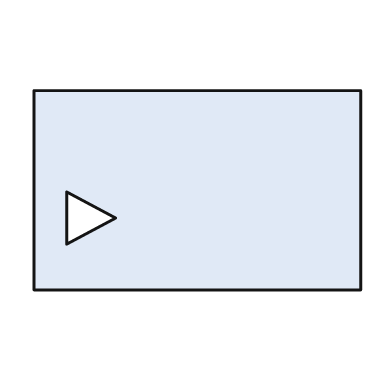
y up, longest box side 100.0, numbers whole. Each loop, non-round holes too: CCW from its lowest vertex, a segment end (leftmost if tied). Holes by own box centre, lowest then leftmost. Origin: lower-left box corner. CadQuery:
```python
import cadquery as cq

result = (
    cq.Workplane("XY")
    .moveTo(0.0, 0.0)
    .lineTo(100.0, 0.0)
    .lineTo(100.0, 61.0)
    .lineTo(0.0, 61.0)
    .close()
    .moveTo(10.0, 14.0)
    .lineTo(25.0, 22.0)
    .lineTo(10.0, 30.0)
    .close()
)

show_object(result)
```